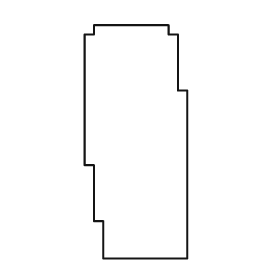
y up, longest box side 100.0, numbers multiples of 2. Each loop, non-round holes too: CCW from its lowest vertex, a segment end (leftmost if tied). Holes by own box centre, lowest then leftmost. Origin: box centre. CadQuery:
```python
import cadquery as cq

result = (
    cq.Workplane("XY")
    .moveTo(-14.0, -50.0)
    .lineTo(22.0, -50.0)
    .lineTo(22.0, 22.0)
    .lineTo(18.0, 22.0)
    .lineTo(18.0, 46.0)
    .lineTo(14.0, 46.0)
    .lineTo(14.0, 50.0)
    .lineTo(-18.0, 50.0)
    .lineTo(-18.0, 46.0)
    .lineTo(-22.0, 46.0)
    .lineTo(-22.0, -10.0)
    .lineTo(-18.0, -10.0)
    .lineTo(-18.0, -34.0)
    .lineTo(-14.0, -34.0)
    .close()
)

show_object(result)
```